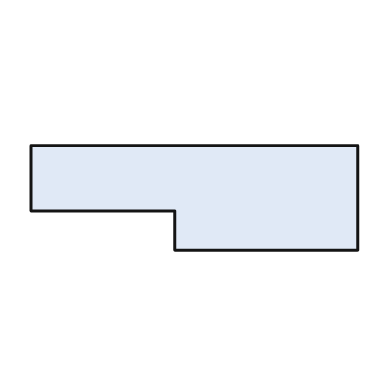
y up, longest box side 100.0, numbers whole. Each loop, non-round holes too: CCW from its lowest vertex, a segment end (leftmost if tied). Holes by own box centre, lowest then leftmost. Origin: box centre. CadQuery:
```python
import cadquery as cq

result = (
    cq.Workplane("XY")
    .moveTo(-6.0, -16.0)
    .lineTo(50.0, -16.0)
    .lineTo(50.0, 16.0)
    .lineTo(-50.0, 16.0)
    .lineTo(-50.0, -4.0)
    .lineTo(-6.0, -4.0)
    .close()
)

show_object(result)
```